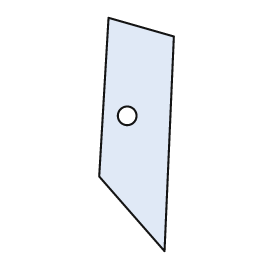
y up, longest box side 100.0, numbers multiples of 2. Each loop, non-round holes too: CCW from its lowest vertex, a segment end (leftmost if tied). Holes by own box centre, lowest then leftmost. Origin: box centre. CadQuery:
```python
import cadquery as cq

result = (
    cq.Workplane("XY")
    .moveTo(12.0, -50.0)
    .lineTo(16.0, 42.0)
    .lineTo(-12.0, 50.0)
    .lineTo(-16.0, -18.0)
    .close()
    .moveTo(-4.0, 8.0)
    .circle(4.0)
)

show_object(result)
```